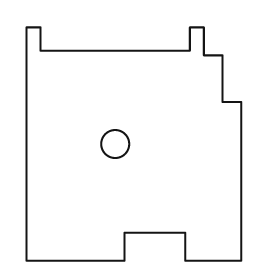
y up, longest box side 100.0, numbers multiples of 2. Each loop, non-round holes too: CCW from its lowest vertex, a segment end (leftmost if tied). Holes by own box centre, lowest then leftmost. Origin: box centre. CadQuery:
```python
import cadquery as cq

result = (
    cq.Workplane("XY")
    .moveTo(-46.0, -50.0)
    .lineTo(-4.0, -50.0)
    .lineTo(-4.0, -38.0)
    .lineTo(22.0, -38.0)
    .lineTo(22.0, -50.0)
    .lineTo(46.0, -50.0)
    .lineTo(46.0, 18.0)
    .lineTo(38.0, 18.0)
    .lineTo(38.0, 38.0)
    .lineTo(30.0, 38.0)
    .lineTo(30.0, 50.0)
    .lineTo(24.0, 50.0)
    .lineTo(24.0, 40.0)
    .lineTo(-40.0, 40.0)
    .lineTo(-40.0, 50.0)
    .lineTo(-46.0, 50.0)
    .close()
    .moveTo(-8.0, 0.0)
    .circle(6.0)
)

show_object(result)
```